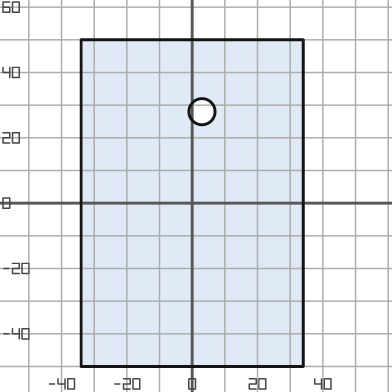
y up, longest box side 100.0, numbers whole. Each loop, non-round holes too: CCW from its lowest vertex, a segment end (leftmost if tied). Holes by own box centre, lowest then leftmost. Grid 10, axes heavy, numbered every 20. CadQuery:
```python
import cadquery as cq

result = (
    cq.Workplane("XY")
    .moveTo(-34.0, -50.0)
    .lineTo(34.0, -50.0)
    .lineTo(34.0, 50.0)
    .lineTo(-34.0, 50.0)
    .close()
    .moveTo(3.0, 28.0)
    .circle(4.0)
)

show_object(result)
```